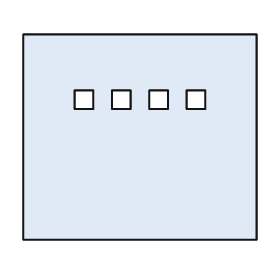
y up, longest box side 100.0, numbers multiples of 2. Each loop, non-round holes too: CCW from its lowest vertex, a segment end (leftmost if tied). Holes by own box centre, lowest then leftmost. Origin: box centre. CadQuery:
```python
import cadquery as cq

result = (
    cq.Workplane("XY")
    .moveTo(-50.0, -44.0)
    .lineTo(50.0, -44.0)
    .lineTo(50.0, 44.0)
    .lineTo(-50.0, 44.0)
    .close()
    .moveTo(-28.0, 12.0)
    .lineTo(-20.0, 12.0)
    .lineTo(-20.0, 20.0)
    .lineTo(-28.0, 20.0)
    .close()
    .moveTo(-12.0, 12.0)
    .lineTo(-4.0, 12.0)
    .lineTo(-4.0, 20.0)
    .lineTo(-12.0, 20.0)
    .close()
    .moveTo(4.0, 12.0)
    .lineTo(12.0, 12.0)
    .lineTo(12.0, 20.0)
    .lineTo(4.0, 20.0)
    .close()
    .moveTo(20.0, 12.0)
    .lineTo(28.0, 12.0)
    .lineTo(28.0, 20.0)
    .lineTo(20.0, 20.0)
    .close()
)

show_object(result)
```